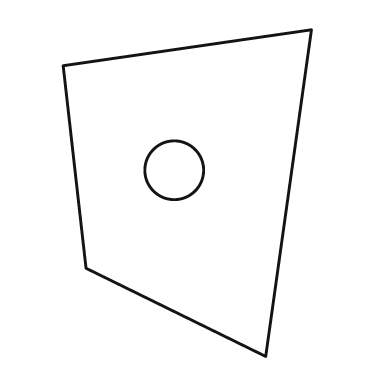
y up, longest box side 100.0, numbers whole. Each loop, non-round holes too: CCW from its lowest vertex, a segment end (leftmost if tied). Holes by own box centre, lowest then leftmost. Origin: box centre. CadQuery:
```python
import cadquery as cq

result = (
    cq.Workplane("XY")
    .moveTo(24.0, -50.0)
    .lineTo(38.0, 50.0)
    .lineTo(-38.0, 39.0)
    .lineTo(-31.0, -23.0)
    .close()
    .moveTo(-4.0, 7.0)
    .circle(9.0)
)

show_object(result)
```